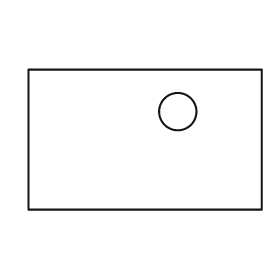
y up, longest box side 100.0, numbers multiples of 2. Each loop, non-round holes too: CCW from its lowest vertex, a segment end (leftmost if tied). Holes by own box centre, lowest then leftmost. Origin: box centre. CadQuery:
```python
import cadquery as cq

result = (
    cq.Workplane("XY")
    .moveTo(-50.0, -30.0)
    .lineTo(50.0, -30.0)
    .lineTo(50.0, 30.0)
    .lineTo(-50.0, 30.0)
    .close()
    .moveTo(14.0, 12.0)
    .circle(8.0)
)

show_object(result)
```